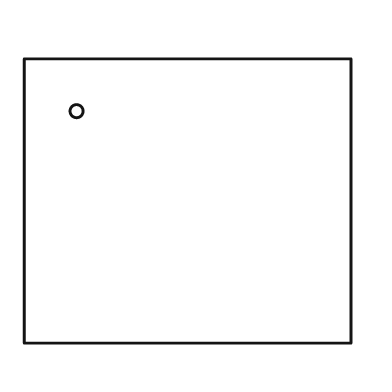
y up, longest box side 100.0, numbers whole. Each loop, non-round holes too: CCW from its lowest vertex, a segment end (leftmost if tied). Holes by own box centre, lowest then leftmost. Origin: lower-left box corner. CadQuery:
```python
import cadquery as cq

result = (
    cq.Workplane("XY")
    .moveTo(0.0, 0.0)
    .lineTo(100.0, 0.0)
    .lineTo(100.0, 87.0)
    .lineTo(0.0, 87.0)
    .close()
    .moveTo(16.0, 71.0)
    .circle(2.0)
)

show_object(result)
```